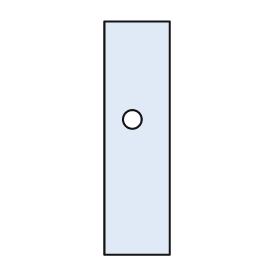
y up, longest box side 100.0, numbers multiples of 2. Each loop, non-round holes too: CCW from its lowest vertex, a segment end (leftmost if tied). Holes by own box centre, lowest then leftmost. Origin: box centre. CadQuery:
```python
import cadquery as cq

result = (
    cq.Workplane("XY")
    .moveTo(-14.0, -50.0)
    .lineTo(14.0, -50.0)
    .lineTo(14.0, 50.0)
    .lineTo(-14.0, 50.0)
    .close()
    .moveTo(-2.0, 8.0)
    .circle(4.0)
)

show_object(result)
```